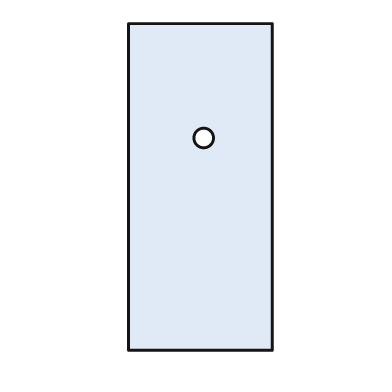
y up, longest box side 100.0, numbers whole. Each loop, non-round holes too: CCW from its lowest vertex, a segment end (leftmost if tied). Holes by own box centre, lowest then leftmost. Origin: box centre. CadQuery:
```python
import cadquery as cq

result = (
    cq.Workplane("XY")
    .moveTo(-22.0, -50.0)
    .lineTo(22.0, -50.0)
    .lineTo(22.0, 50.0)
    .lineTo(-22.0, 50.0)
    .close()
    .moveTo(1.0, 15.0)
    .circle(3.0)
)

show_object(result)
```